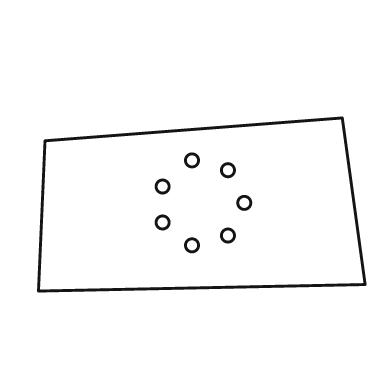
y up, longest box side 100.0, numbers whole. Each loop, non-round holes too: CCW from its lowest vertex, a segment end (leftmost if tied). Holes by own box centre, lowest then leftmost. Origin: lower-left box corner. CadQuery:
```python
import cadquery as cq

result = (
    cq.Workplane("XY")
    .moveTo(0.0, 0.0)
    .lineTo(100.0, 2.0)
    .lineTo(93.0, 53.0)
    .lineTo(2.0, 46.0)
    .close()
    .moveTo(47.0, 14.0)
    .circle(2.0)
    .moveTo(58.0, 17.0)
    .circle(2.0)
    .moveTo(38.0, 21.0)
    .circle(2.0)
    .moveTo(63.0, 27.0)
    .circle(2.0)
    .moveTo(38.0, 32.0)
    .circle(2.0)
    .moveTo(58.0, 37.0)
    .circle(2.0)
    .moveTo(47.0, 40.0)
    .circle(2.0)
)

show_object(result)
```